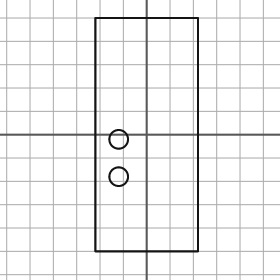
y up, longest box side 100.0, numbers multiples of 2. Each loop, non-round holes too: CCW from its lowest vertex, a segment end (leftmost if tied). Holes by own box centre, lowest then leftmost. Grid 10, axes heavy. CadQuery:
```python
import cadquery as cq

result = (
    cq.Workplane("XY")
    .moveTo(-22.0, -50.0)
    .lineTo(22.0, -50.0)
    .lineTo(22.0, 50.0)
    .lineTo(-22.0, 50.0)
    .close()
    .moveTo(-12.0, -18.0)
    .circle(4.0)
    .moveTo(-12.0, -2.0)
    .circle(4.0)
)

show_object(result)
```